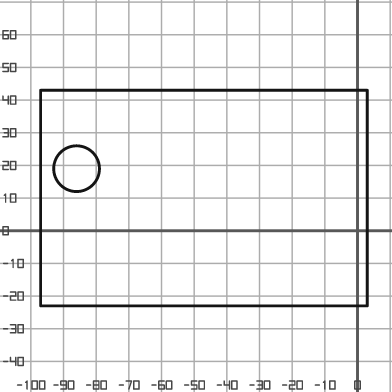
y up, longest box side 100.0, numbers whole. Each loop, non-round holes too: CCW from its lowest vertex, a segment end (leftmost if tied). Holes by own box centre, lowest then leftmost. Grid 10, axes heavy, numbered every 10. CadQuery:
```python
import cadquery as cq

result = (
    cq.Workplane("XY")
    .moveTo(-97.0, -23.0)
    .lineTo(3.0, -23.0)
    .lineTo(3.0, 43.0)
    .lineTo(-97.0, 43.0)
    .close()
    .moveTo(-86.0, 19.0)
    .circle(7.0)
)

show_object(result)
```